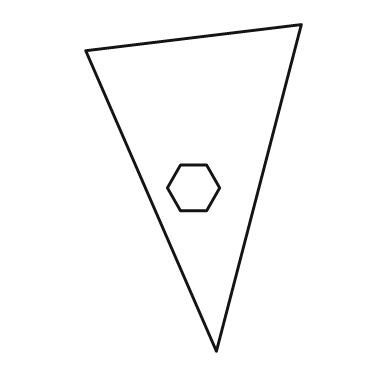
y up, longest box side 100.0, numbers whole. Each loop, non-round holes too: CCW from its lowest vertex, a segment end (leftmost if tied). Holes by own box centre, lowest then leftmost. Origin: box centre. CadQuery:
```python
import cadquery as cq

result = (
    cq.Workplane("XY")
    .moveTo(7.0, -50.0)
    .lineTo(33.0, 50.0)
    .lineTo(-33.0, 42.0)
    .close()
    .moveTo(-4.0, -7.0)
    .lineTo(4.0, -7.0)
    .lineTo(8.0, 0.0)
    .lineTo(4.0, 7.0)
    .lineTo(-4.0, 7.0)
    .lineTo(-8.0, 0.0)
    .close()
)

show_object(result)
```